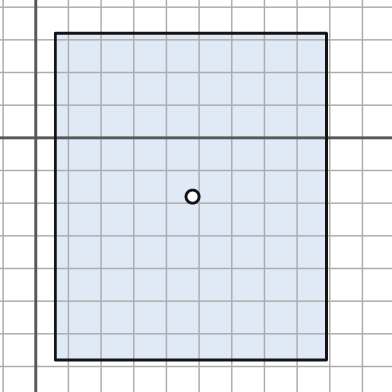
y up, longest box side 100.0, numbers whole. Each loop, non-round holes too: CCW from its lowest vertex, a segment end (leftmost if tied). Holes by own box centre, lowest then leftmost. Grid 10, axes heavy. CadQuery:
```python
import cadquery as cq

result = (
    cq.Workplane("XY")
    .moveTo(6.0, -68.0)
    .lineTo(89.0, -68.0)
    .lineTo(89.0, 32.0)
    .lineTo(6.0, 32.0)
    .close()
    .moveTo(48.0, -18.0)
    .circle(2.0)
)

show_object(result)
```